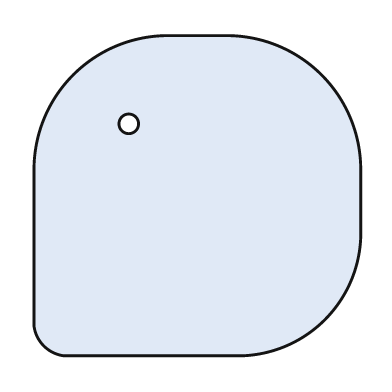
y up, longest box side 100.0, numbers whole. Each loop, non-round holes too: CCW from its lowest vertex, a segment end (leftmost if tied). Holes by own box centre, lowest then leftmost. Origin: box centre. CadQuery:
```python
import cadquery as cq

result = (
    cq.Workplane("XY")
    .moveTo(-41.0, -49.0)
    .lineTo(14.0, -49.0)
    .threePointArc((39.0, -38.0), (50.0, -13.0))
    .lineTo(50.0, 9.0)
    .threePointArc((38.0, 37.0), (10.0, 49.0))
    .lineTo(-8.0, 49.0)
    .threePointArc((-38.0, 37.0), (-50.0, 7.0))
    .lineTo(-50.0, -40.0)
    .threePointArc((-47.0, -46.0), (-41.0, -49.0))
    .close()
    .moveTo(-21.0, 22.0)
    .circle(3.0)
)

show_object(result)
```